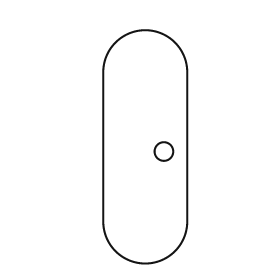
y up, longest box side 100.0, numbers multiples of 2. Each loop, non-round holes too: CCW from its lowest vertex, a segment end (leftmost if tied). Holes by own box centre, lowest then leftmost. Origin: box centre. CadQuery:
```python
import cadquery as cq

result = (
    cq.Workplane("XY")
    .moveTo(-18.0, -32.0)
    .threePointArc((0.0, -50.0), (18.0, -32.0))
    .lineTo(18.0, 32.0)
    .threePointArc((0.0, 50.0), (-18.0, 32.0))
    .close()
    .moveTo(8.0, -2.0)
    .circle(4.0)
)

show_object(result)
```